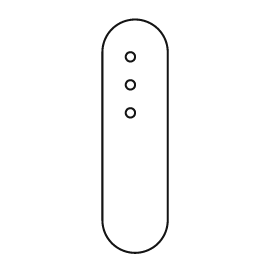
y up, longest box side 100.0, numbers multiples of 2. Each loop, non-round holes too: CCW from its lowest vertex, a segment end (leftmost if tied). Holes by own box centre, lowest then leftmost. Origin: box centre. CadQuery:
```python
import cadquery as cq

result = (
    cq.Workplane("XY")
    .moveTo(-14.0, -36.0)
    .threePointArc((0.0, -50.0), (14.0, -36.0))
    .lineTo(14.0, 36.0)
    .threePointArc((0.0, 50.0), (-14.0, 36.0))
    .close()
    .moveTo(-2.0, 10.0)
    .circle(2.0)
    .moveTo(-2.0, 22.0)
    .circle(2.0)
    .moveTo(-2.0, 34.0)
    .circle(2.0)
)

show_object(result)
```